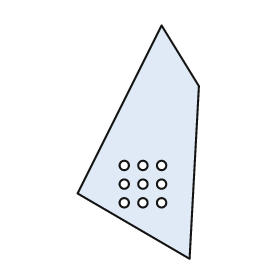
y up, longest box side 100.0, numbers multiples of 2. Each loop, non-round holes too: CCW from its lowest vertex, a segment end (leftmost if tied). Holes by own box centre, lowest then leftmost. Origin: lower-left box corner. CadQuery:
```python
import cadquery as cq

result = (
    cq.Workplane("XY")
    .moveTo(48.0, 0.0)
    .lineTo(52.0, 74.0)
    .lineTo(36.0, 100.0)
    .lineTo(0.0, 28.0)
    .close()
    .moveTo(20.0, 24.0)
    .circle(2.0)
    .moveTo(28.0, 24.0)
    .circle(2.0)
    .moveTo(36.0, 24.0)
    .circle(2.0)
    .moveTo(20.0, 32.0)
    .circle(2.0)
    .moveTo(28.0, 32.0)
    .circle(2.0)
    .moveTo(36.0, 32.0)
    .circle(2.0)
    .moveTo(20.0, 40.0)
    .circle(2.0)
    .moveTo(28.0, 40.0)
    .circle(2.0)
    .moveTo(36.0, 40.0)
    .circle(2.0)
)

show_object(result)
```